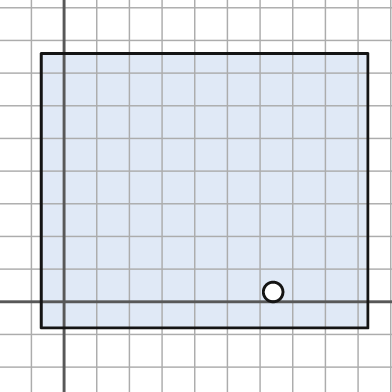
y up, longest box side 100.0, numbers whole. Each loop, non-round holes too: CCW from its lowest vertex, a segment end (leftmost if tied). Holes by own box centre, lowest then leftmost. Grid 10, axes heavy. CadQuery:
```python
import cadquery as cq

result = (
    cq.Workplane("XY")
    .moveTo(-7.0, -8.0)
    .lineTo(93.0, -8.0)
    .lineTo(93.0, 76.0)
    .lineTo(-7.0, 76.0)
    .close()
    .moveTo(64.0, 3.0)
    .circle(3.0)
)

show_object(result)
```